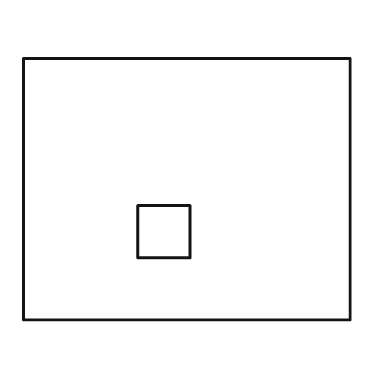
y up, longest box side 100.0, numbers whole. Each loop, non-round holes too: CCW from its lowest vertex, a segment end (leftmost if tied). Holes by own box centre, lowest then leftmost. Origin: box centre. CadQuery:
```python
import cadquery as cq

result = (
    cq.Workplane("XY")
    .moveTo(-50.0, -40.0)
    .lineTo(50.0, -40.0)
    .lineTo(50.0, 40.0)
    .lineTo(-50.0, 40.0)
    .close()
    .moveTo(-15.0, -21.0)
    .lineTo(1.0, -21.0)
    .lineTo(1.0, -5.0)
    .lineTo(-15.0, -5.0)
    .close()
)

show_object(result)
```